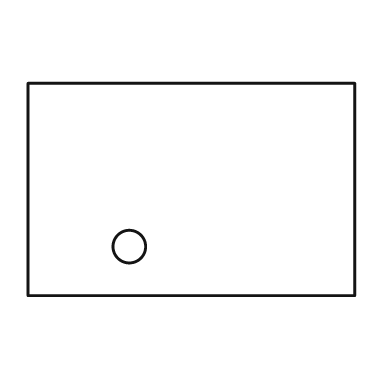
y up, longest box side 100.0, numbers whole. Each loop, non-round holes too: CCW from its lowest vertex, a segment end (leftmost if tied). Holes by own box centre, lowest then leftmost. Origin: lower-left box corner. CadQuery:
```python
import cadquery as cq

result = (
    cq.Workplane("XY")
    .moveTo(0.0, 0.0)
    .lineTo(100.0, 0.0)
    .lineTo(100.0, 65.0)
    .lineTo(0.0, 65.0)
    .close()
    .moveTo(31.0, 15.0)
    .circle(5.0)
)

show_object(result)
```